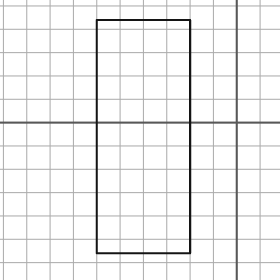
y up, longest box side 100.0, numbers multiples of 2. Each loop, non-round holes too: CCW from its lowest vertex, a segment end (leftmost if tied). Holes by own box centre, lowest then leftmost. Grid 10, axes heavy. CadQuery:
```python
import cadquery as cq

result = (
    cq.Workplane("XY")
    .moveTo(-60.0, -56.0)
    .lineTo(-20.0, -56.0)
    .lineTo(-20.0, 44.0)
    .lineTo(-60.0, 44.0)
    .close()
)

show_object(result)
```